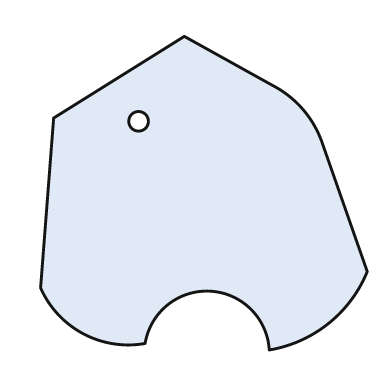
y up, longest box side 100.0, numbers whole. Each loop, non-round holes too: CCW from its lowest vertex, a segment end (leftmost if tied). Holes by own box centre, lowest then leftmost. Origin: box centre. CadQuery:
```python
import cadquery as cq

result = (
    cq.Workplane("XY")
    .moveTo(20.0, -48.0)
    .threePointArc((38.0, -40.0), (50.0, -24.0))
    .lineTo(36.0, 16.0)
    .threePointArc((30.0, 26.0), (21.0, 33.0))
    .lineTo(-6.0, 48.0)
    .lineTo(-46.0, 23.0)
    .lineTo(-50.0, -29.0)
    .threePointArc((-37.0, -43.0), (-18.0, -46.0))
    .threePointArc((2.0, -30.0), (20.0, -48.0))
    .close()
    .moveTo(-20.0, 22.0)
    .circle(3.0)
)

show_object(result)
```